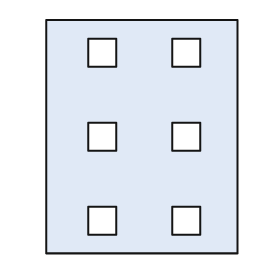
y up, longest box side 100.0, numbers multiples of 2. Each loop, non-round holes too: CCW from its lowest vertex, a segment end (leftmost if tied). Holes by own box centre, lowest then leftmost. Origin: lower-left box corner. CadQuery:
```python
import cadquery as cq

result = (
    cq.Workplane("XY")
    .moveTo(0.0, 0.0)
    .lineTo(82.0, 0.0)
    .lineTo(82.0, 100.0)
    .lineTo(0.0, 100.0)
    .close()
    .moveTo(18.0, 8.0)
    .lineTo(30.0, 8.0)
    .lineTo(30.0, 20.0)
    .lineTo(18.0, 20.0)
    .close()
    .moveTo(54.0, 8.0)
    .lineTo(66.0, 8.0)
    .lineTo(66.0, 20.0)
    .lineTo(54.0, 20.0)
    .close()
    .moveTo(18.0, 44.0)
    .lineTo(30.0, 44.0)
    .lineTo(30.0, 56.0)
    .lineTo(18.0, 56.0)
    .close()
    .moveTo(54.0, 44.0)
    .lineTo(66.0, 44.0)
    .lineTo(66.0, 56.0)
    .lineTo(54.0, 56.0)
    .close()
    .moveTo(18.0, 80.0)
    .lineTo(30.0, 80.0)
    .lineTo(30.0, 92.0)
    .lineTo(18.0, 92.0)
    .close()
    .moveTo(54.0, 80.0)
    .lineTo(66.0, 80.0)
    .lineTo(66.0, 92.0)
    .lineTo(54.0, 92.0)
    .close()
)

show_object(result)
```